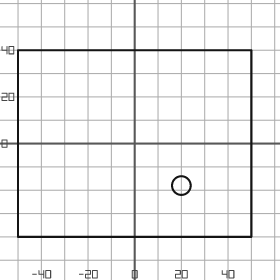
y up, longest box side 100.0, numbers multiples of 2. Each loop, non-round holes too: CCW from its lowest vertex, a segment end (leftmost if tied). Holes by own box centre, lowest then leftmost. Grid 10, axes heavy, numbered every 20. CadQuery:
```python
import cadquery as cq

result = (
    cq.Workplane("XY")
    .moveTo(-50.0, -40.0)
    .lineTo(50.0, -40.0)
    .lineTo(50.0, 40.0)
    .lineTo(-50.0, 40.0)
    .close()
    .moveTo(20.0, -18.0)
    .circle(4.0)
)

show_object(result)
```